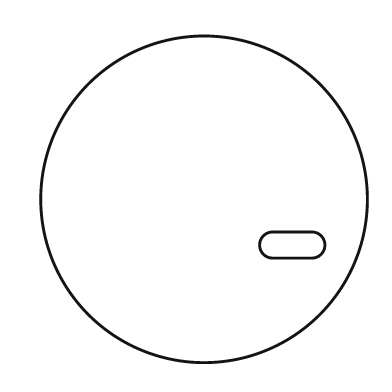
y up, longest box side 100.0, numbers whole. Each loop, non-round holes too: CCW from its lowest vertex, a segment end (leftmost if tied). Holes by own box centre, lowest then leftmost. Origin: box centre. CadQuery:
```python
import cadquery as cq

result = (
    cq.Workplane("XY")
    .moveTo(0.0, 0.0)
    .circle(50.0)
    .moveTo(21.0, -18.0)
    .lineTo(33.0, -18.0)
    .threePointArc((37.0, -14.0), (33.0, -10.0))
    .lineTo(21.0, -10.0)
    .threePointArc((17.0, -14.0), (21.0, -18.0))
    .close()
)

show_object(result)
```